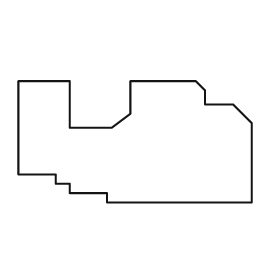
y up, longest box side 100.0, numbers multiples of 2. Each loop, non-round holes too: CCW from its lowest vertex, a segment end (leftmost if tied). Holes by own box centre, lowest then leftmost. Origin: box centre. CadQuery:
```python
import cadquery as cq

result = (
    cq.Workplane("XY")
    .moveTo(-12.0, -26.0)
    .lineTo(50.0, -26.0)
    .lineTo(50.0, 8.0)
    .lineTo(42.0, 16.0)
    .lineTo(30.0, 16.0)
    .lineTo(30.0, 22.0)
    .lineTo(26.0, 26.0)
    .lineTo(-2.0, 26.0)
    .lineTo(-2.0, 12.0)
    .lineTo(-10.0, 6.0)
    .lineTo(-28.0, 6.0)
    .lineTo(-28.0, 26.0)
    .lineTo(-50.0, 26.0)
    .lineTo(-50.0, -14.0)
    .lineTo(-34.0, -14.0)
    .lineTo(-34.0, -18.0)
    .lineTo(-28.0, -18.0)
    .lineTo(-28.0, -22.0)
    .lineTo(-12.0, -22.0)
    .close()
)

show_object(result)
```